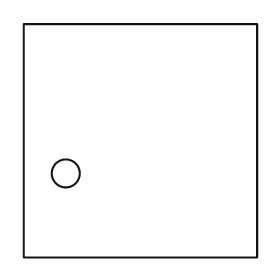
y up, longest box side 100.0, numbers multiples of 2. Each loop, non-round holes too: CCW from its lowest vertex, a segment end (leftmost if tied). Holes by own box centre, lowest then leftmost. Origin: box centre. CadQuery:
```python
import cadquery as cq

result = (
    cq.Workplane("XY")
    .moveTo(-50.0, -50.0)
    .lineTo(50.0, -50.0)
    .lineTo(50.0, 50.0)
    .lineTo(-50.0, 50.0)
    .close()
    .moveTo(-32.0, -14.0)
    .circle(6.0)
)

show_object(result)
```